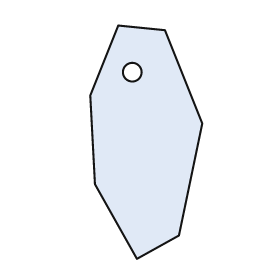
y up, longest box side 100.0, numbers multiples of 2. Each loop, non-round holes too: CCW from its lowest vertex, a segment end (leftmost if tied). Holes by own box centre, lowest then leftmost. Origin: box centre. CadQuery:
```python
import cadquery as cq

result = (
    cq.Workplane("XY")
    .moveTo(-4.0, -50.0)
    .lineTo(14.0, -40.0)
    .lineTo(24.0, 8.0)
    .lineTo(8.0, 48.0)
    .lineTo(-12.0, 50.0)
    .lineTo(-24.0, 20.0)
    .lineTo(-22.0, -18.0)
    .close()
    .moveTo(-6.0, 30.0)
    .circle(4.0)
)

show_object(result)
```